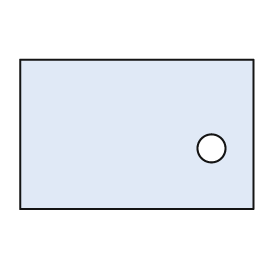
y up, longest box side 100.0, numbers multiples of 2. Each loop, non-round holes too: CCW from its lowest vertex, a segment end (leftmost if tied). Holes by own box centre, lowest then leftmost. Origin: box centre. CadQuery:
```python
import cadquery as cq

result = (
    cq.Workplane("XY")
    .moveTo(-50.0, -32.0)
    .lineTo(50.0, -32.0)
    .lineTo(50.0, 32.0)
    .lineTo(-50.0, 32.0)
    .close()
    .moveTo(32.0, -6.0)
    .circle(6.0)
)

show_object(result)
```